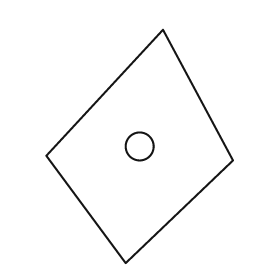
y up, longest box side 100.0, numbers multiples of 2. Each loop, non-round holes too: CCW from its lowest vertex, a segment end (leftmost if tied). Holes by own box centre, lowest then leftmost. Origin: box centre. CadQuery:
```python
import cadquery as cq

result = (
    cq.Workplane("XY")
    .moveTo(-6.0, -50.0)
    .lineTo(40.0, -6.0)
    .lineTo(10.0, 50.0)
    .lineTo(-40.0, -4.0)
    .close()
    .moveTo(0.0, 0.0)
    .circle(6.0)
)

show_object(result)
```